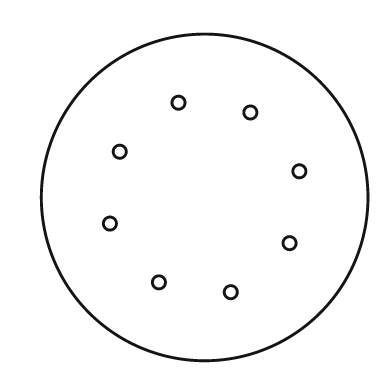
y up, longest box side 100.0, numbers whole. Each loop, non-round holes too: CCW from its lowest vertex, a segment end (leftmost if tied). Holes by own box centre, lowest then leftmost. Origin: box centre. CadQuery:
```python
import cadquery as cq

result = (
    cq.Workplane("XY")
    .moveTo(0.0, 0.0)
    .circle(50.0)
    .moveTo(8.0, -29.0)
    .circle(2.0)
    .moveTo(-14.0, -26.0)
    .circle(2.0)
    .moveTo(26.0, -14.0)
    .circle(2.0)
    .moveTo(-29.0, -8.0)
    .circle(2.0)
    .moveTo(29.0, 8.0)
    .circle(2.0)
    .moveTo(-26.0, 14.0)
    .circle(2.0)
    .moveTo(14.0, 26.0)
    .circle(2.0)
    .moveTo(-8.0, 29.0)
    .circle(2.0)
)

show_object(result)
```